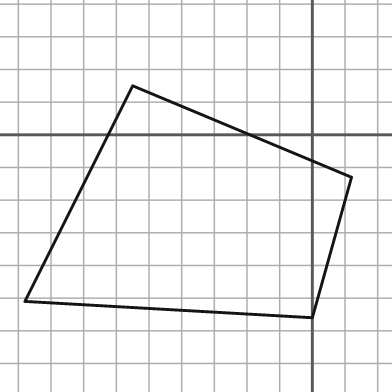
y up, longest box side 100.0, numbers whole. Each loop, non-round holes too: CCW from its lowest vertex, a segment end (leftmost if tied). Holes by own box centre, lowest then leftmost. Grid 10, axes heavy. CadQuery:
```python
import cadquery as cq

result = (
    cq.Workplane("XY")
    .moveTo(0.0, -56.0)
    .lineTo(12.0, -13.0)
    .lineTo(-55.0, 15.0)
    .lineTo(-88.0, -51.0)
    .close()
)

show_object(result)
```